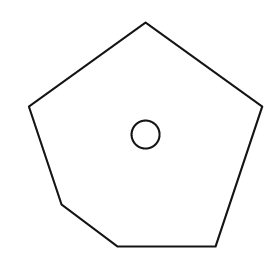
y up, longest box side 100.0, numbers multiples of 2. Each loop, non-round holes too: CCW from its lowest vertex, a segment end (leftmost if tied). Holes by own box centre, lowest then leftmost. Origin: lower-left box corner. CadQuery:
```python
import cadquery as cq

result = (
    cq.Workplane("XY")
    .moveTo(38.0, 0.0)
    .lineTo(80.0, 0.0)
    .lineTo(100.0, 60.0)
    .lineTo(50.0, 96.0)
    .lineTo(0.0, 60.0)
    .lineTo(14.0, 18.0)
    .close()
    .moveTo(50.0, 48.0)
    .circle(6.0)
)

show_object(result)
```